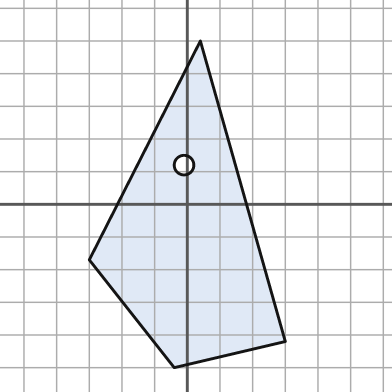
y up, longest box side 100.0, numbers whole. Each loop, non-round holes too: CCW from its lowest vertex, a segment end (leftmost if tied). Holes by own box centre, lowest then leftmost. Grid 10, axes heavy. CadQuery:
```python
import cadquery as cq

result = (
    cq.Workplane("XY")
    .moveTo(-4.0, -50.0)
    .lineTo(30.0, -42.0)
    .lineTo(4.0, 50.0)
    .lineTo(-30.0, -17.0)
    .close()
    .moveTo(-1.0, 12.0)
    .circle(3.0)
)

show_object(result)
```